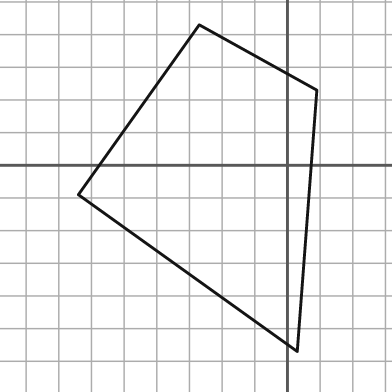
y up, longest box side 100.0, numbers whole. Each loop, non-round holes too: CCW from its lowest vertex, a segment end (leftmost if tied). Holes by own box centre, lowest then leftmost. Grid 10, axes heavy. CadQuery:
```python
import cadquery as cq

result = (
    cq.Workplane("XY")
    .moveTo(3.0, -57.0)
    .lineTo(9.0, 23.0)
    .lineTo(-27.0, 43.0)
    .lineTo(-64.0, -9.0)
    .close()
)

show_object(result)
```